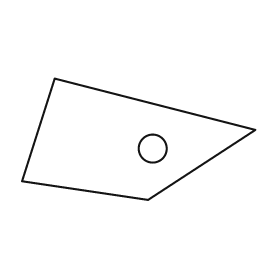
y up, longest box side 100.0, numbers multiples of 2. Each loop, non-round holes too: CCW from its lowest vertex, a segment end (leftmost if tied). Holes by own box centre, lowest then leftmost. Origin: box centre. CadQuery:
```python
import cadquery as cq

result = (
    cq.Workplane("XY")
    .moveTo(4.0, -26.0)
    .lineTo(50.0, 4.0)
    .lineTo(-36.0, 26.0)
    .lineTo(-50.0, -18.0)
    .close()
    .moveTo(6.0, -4.0)
    .circle(6.0)
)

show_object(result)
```